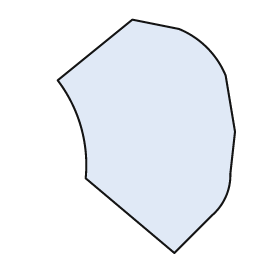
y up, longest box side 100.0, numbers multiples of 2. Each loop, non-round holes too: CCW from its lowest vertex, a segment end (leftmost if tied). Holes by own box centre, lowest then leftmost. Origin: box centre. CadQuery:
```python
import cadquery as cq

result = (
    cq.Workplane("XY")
    .moveTo(12.0, -50.0)
    .lineTo(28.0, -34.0)
    .threePointArc((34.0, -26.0), (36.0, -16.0))
    .lineTo(38.0, 2.0)
    .lineTo(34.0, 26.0)
    .threePointArc((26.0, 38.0), (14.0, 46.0))
    .lineTo(-6.0, 50.0)
    .lineTo(-38.0, 24.0)
    .threePointArc((-28.0, 4.0), (-26.0, -18.0))
    .close()
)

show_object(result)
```